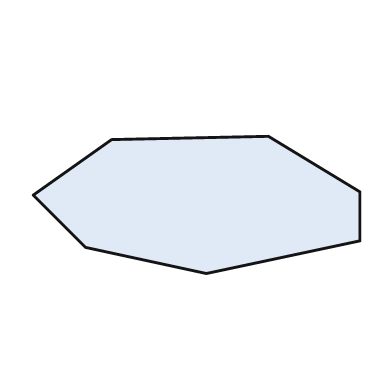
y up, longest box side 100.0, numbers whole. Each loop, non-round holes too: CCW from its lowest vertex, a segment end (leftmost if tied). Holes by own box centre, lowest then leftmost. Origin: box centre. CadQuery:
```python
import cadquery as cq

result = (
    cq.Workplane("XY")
    .moveTo(3.0, -21.0)
    .lineTo(50.0, -11.0)
    .lineTo(50.0, 4.0)
    .lineTo(22.0, 21.0)
    .lineTo(-26.0, 20.0)
    .lineTo(-50.0, 3.0)
    .lineTo(-34.0, -13.0)
    .close()
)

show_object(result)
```